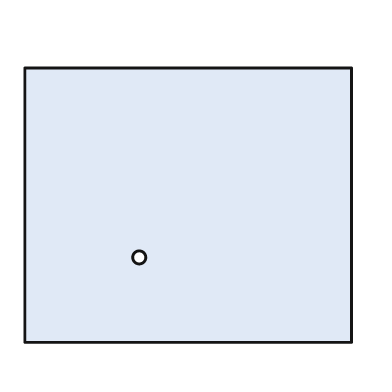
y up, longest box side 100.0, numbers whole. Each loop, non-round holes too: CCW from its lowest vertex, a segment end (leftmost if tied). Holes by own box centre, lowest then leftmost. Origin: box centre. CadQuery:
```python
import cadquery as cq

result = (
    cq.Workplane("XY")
    .moveTo(-50.0, -42.0)
    .lineTo(50.0, -42.0)
    .lineTo(50.0, 42.0)
    .lineTo(-50.0, 42.0)
    .close()
    .moveTo(-15.0, -16.0)
    .circle(2.0)
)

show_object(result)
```